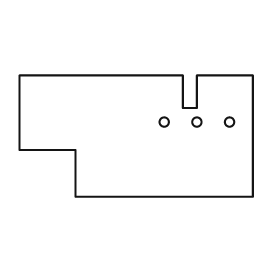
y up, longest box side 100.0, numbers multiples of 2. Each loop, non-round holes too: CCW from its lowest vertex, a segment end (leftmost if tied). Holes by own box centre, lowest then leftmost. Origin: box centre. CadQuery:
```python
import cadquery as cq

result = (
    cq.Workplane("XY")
    .moveTo(-26.0, -26.0)
    .lineTo(50.0, -26.0)
    .lineTo(50.0, 26.0)
    .lineTo(26.0, 26.0)
    .lineTo(26.0, 12.0)
    .lineTo(20.0, 12.0)
    .lineTo(20.0, 26.0)
    .lineTo(-50.0, 26.0)
    .lineTo(-50.0, -6.0)
    .lineTo(-26.0, -6.0)
    .close()
    .moveTo(12.0, 6.0)
    .circle(2.0)
    .moveTo(26.0, 6.0)
    .circle(2.0)
    .moveTo(40.0, 6.0)
    .circle(2.0)
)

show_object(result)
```